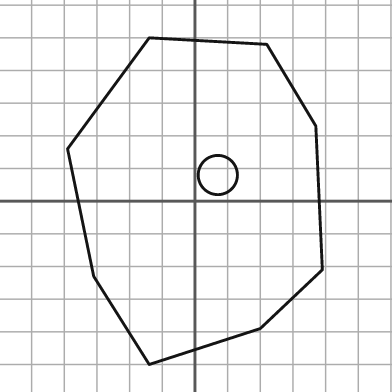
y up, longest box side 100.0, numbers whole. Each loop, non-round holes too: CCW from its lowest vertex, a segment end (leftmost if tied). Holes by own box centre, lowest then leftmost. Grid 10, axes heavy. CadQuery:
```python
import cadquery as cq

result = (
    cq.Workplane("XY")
    .moveTo(-14.0, -50.0)
    .lineTo(20.0, -39.0)
    .lineTo(39.0, -21.0)
    .lineTo(37.0, 23.0)
    .lineTo(22.0, 48.0)
    .lineTo(-14.0, 50.0)
    .lineTo(-39.0, 16.0)
    .lineTo(-31.0, -23.0)
    .close()
    .moveTo(7.0, 8.0)
    .circle(6.0)
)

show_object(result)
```